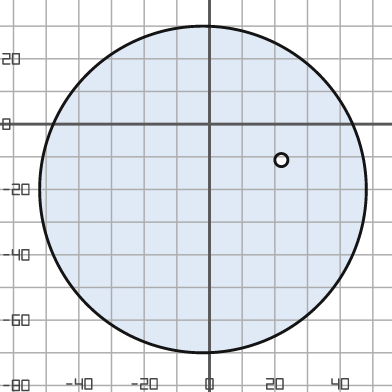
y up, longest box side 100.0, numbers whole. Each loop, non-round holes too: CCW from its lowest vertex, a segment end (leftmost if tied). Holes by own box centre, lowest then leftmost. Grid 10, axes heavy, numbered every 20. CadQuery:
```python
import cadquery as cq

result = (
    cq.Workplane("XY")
    .moveTo(-2.0, -20.0)
    .circle(50.0)
    .moveTo(22.0, -11.0)
    .circle(2.0)
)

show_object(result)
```